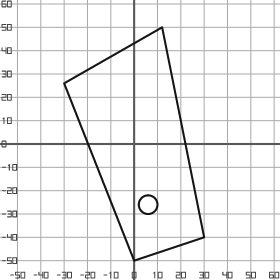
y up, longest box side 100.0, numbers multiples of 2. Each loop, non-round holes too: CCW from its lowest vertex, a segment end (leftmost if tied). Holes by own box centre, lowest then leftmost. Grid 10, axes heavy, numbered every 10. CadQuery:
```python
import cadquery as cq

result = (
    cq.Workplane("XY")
    .moveTo(0.0, -50.0)
    .lineTo(30.0, -40.0)
    .lineTo(12.0, 50.0)
    .lineTo(-30.0, 26.0)
    .close()
    .moveTo(6.0, -26.0)
    .circle(4.0)
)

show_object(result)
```